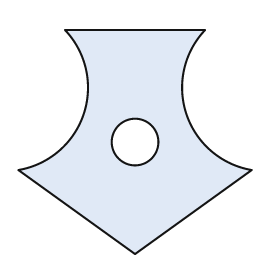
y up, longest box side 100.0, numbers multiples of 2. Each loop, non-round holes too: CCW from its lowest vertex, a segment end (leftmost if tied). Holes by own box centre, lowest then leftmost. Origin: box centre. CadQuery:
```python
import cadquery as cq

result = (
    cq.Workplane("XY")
    .moveTo(0.0, -48.0)
    .lineTo(50.0, -12.0)
    .threePointArc((22.0, 12.0), (30.0, 48.0))
    .lineTo(-30.0, 48.0)
    .threePointArc((-22.0, 12.0), (-50.0, -12.0))
    .close()
    .moveTo(0.0, 0.0)
    .circle(10.0)
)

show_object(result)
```